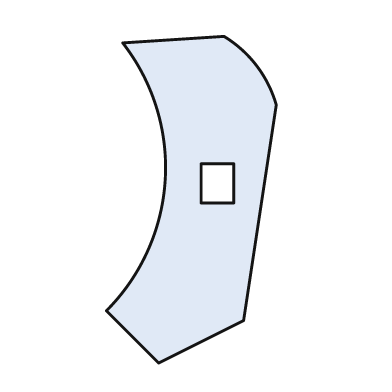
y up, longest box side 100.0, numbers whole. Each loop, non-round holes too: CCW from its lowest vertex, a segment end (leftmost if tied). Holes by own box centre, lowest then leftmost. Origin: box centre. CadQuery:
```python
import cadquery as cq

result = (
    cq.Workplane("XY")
    .moveTo(-10.0, -50.0)
    .lineTo(16.0, -37.0)
    .lineTo(26.0, 29.0)
    .threePointArc((20.0, 41.0), (10.0, 50.0))
    .lineTo(-21.0, 48.0)
    .threePointArc((-8.0, 6.0), (-26.0, -34.0))
    .close()
    .moveTo(3.0, -1.0)
    .lineTo(13.0, -1.0)
    .lineTo(13.0, 11.0)
    .lineTo(3.0, 11.0)
    .close()
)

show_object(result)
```